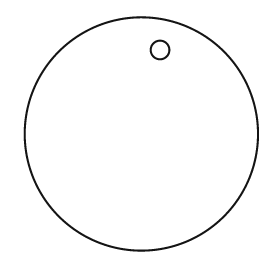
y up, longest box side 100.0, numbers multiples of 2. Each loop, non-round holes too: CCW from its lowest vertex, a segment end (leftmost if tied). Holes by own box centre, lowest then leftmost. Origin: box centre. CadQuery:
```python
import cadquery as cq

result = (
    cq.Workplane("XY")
    .moveTo(0.0, 0.0)
    .circle(50.0)
    .moveTo(8.0, 36.0)
    .circle(4.0)
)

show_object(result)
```